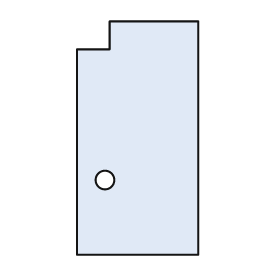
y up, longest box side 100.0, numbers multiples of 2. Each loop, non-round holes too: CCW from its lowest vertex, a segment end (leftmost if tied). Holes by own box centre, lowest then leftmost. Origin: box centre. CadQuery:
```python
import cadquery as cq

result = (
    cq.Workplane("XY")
    .moveTo(-26.0, -50.0)
    .lineTo(26.0, -50.0)
    .lineTo(26.0, 50.0)
    .lineTo(-12.0, 50.0)
    .lineTo(-12.0, 38.0)
    .lineTo(-26.0, 38.0)
    .close()
    .moveTo(-14.0, -18.0)
    .circle(4.0)
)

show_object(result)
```